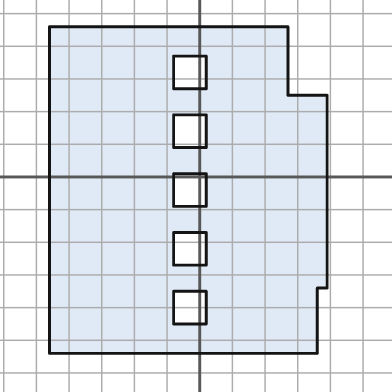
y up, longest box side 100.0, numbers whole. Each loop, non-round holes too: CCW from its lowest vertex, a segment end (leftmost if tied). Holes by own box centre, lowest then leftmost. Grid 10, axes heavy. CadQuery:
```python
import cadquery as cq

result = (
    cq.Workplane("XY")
    .moveTo(-46.0, -54.0)
    .lineTo(36.0, -54.0)
    .lineTo(36.0, -34.0)
    .lineTo(39.0, -34.0)
    .lineTo(39.0, 25.0)
    .lineTo(27.0, 25.0)
    .lineTo(27.0, 46.0)
    .lineTo(-46.0, 46.0)
    .close()
    .moveTo(-8.0, -45.0)
    .lineTo(2.0, -45.0)
    .lineTo(2.0, -35.0)
    .lineTo(-8.0, -35.0)
    .close()
    .moveTo(-8.0, -27.0)
    .lineTo(2.0, -27.0)
    .lineTo(2.0, -17.0)
    .lineTo(-8.0, -17.0)
    .close()
    .moveTo(-8.0, -9.0)
    .lineTo(2.0, -9.0)
    .lineTo(2.0, 1.0)
    .lineTo(-8.0, 1.0)
    .close()
    .moveTo(-8.0, 9.0)
    .lineTo(2.0, 9.0)
    .lineTo(2.0, 19.0)
    .lineTo(-8.0, 19.0)
    .close()
    .moveTo(-8.0, 27.0)
    .lineTo(2.0, 27.0)
    .lineTo(2.0, 37.0)
    .lineTo(-8.0, 37.0)
    .close()
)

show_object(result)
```